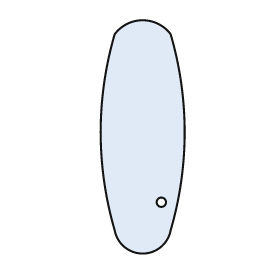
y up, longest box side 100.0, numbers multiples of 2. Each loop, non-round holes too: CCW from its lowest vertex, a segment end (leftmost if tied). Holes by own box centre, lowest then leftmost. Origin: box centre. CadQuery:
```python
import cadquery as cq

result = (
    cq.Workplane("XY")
    .moveTo(-12.0, -40.0)
    .threePointArc((0.0, -50.0), (12.0, -40.0))
    .threePointArc((18.0, 2.0), (12.0, 44.0))
    .threePointArc((0.0, 50.0), (-12.0, 44.0))
    .threePointArc((-18.0, 2.0), (-12.0, -40.0))
    .close()
    .moveTo(8.0, -28.0)
    .circle(2.0)
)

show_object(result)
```